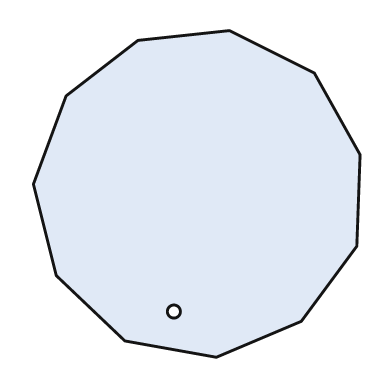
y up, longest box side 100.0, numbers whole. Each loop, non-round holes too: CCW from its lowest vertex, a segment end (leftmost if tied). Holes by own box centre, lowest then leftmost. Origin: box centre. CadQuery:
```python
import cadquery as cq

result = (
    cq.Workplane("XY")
    .moveTo(6.0, -50.0)
    .lineTo(32.0, -39.0)
    .lineTo(49.0, -16.0)
    .lineTo(50.0, 12.0)
    .lineTo(36.0, 37.0)
    .lineTo(10.0, 50.0)
    .lineTo(-18.0, 47.0)
    .lineTo(-40.0, 30.0)
    .lineTo(-50.0, 3.0)
    .lineTo(-43.0, -25.0)
    .lineTo(-22.0, -45.0)
    .close()
    .moveTo(-7.0, -36.0)
    .circle(2.0)
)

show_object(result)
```